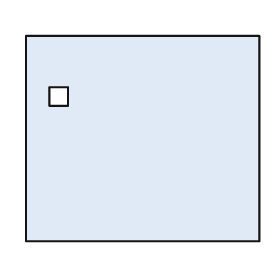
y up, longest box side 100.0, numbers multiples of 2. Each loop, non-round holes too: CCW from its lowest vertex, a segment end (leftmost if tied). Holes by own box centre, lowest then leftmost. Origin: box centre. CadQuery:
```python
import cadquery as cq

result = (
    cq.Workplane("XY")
    .moveTo(-50.0, -44.0)
    .lineTo(50.0, -44.0)
    .lineTo(50.0, 44.0)
    .lineTo(-50.0, 44.0)
    .close()
    .moveTo(-40.0, 14.0)
    .lineTo(-32.0, 14.0)
    .lineTo(-32.0, 22.0)
    .lineTo(-40.0, 22.0)
    .close()
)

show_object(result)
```